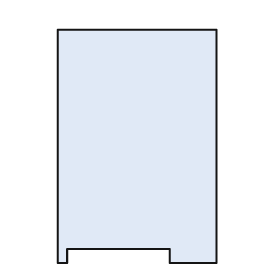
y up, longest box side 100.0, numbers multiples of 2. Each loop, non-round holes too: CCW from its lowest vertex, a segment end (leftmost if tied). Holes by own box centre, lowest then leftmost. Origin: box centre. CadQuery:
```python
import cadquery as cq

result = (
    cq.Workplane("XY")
    .moveTo(-34.0, -50.0)
    .lineTo(-30.0, -50.0)
    .lineTo(-30.0, -44.0)
    .lineTo(14.0, -44.0)
    .lineTo(14.0, -50.0)
    .lineTo(34.0, -50.0)
    .lineTo(34.0, 50.0)
    .lineTo(-34.0, 50.0)
    .close()
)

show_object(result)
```